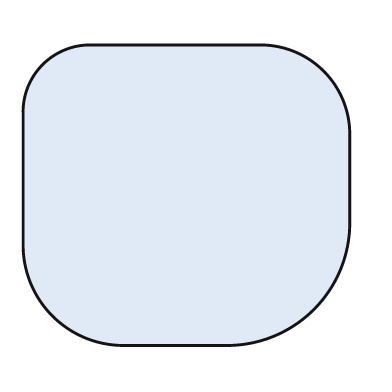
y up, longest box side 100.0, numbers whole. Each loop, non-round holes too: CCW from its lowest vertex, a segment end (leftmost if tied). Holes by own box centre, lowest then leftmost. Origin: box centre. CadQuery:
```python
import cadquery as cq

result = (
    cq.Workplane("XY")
    .moveTo(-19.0, -46.0)
    .lineTo(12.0, -46.0)
    .threePointArc((39.0, -35.0), (50.0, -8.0))
    .lineTo(50.0, 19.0)
    .threePointArc((42.0, 38.0), (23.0, 46.0))
    .lineTo(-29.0, 46.0)
    .threePointArc((-44.0, 40.0), (-50.0, 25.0))
    .lineTo(-50.0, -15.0)
    .threePointArc((-41.0, -37.0), (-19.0, -46.0))
    .close()
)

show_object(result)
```